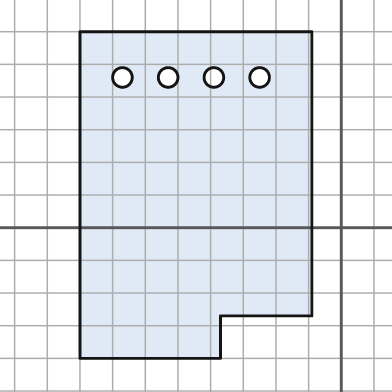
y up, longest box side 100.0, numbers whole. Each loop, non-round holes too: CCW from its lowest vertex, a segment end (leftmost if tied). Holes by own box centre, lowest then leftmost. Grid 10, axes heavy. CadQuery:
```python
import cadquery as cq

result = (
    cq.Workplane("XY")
    .moveTo(-80.0, -40.0)
    .lineTo(-37.0, -40.0)
    .lineTo(-37.0, -27.0)
    .lineTo(-9.0, -27.0)
    .lineTo(-9.0, 60.0)
    .lineTo(-80.0, 60.0)
    .close()
    .moveTo(-67.0, 46.0)
    .circle(3.0)
    .moveTo(-53.0, 46.0)
    .circle(3.0)
    .moveTo(-39.0, 46.0)
    .circle(3.0)
    .moveTo(-25.0, 46.0)
    .circle(3.0)
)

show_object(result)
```